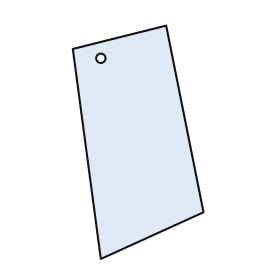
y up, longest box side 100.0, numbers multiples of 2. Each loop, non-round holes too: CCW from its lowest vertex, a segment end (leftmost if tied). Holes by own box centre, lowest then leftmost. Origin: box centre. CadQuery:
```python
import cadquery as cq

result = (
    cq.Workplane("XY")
    .moveTo(-16.0, -50.0)
    .lineTo(28.0, -30.0)
    .lineTo(12.0, 50.0)
    .lineTo(-28.0, 40.0)
    .close()
    .moveTo(-16.0, 36.0)
    .circle(2.0)
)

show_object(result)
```